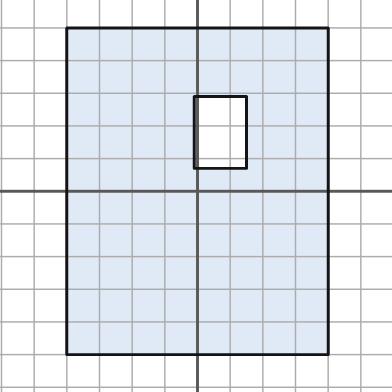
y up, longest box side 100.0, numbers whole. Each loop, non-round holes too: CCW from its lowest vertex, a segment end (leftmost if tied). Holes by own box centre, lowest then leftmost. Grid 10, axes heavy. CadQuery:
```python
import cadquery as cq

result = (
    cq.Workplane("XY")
    .moveTo(-40.0, -50.0)
    .lineTo(40.0, -50.0)
    .lineTo(40.0, 50.0)
    .lineTo(-40.0, 50.0)
    .close()
    .moveTo(-1.0, 7.0)
    .lineTo(15.0, 7.0)
    .lineTo(15.0, 29.0)
    .lineTo(-1.0, 29.0)
    .close()
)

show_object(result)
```